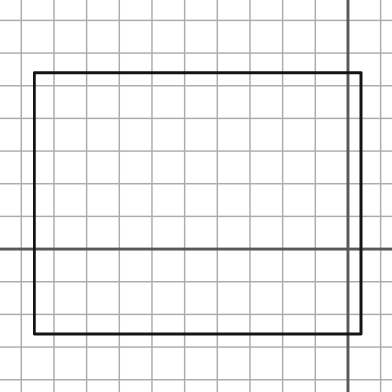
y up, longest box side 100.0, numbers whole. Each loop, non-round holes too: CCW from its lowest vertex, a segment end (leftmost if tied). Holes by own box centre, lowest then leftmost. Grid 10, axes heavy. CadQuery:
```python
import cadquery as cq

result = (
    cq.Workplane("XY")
    .moveTo(-96.0, -26.0)
    .lineTo(4.0, -26.0)
    .lineTo(4.0, 54.0)
    .lineTo(-96.0, 54.0)
    .close()
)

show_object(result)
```